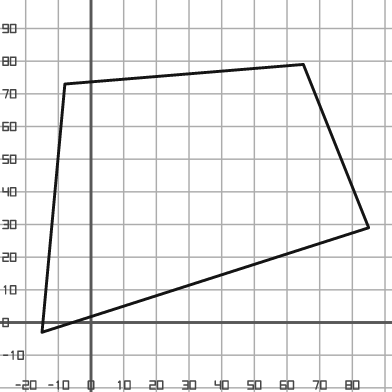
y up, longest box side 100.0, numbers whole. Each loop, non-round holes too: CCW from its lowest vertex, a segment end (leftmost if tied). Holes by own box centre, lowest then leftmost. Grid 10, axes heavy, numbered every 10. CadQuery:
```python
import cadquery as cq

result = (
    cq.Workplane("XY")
    .moveTo(-15.0, -3.0)
    .lineTo(85.0, 29.0)
    .lineTo(65.0, 79.0)
    .lineTo(-8.0, 73.0)
    .close()
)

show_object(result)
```